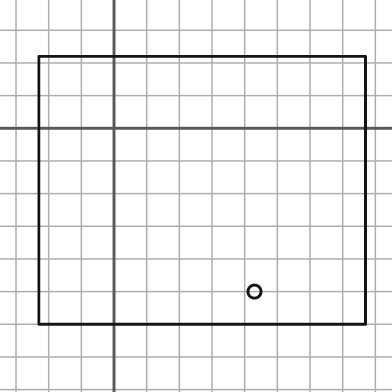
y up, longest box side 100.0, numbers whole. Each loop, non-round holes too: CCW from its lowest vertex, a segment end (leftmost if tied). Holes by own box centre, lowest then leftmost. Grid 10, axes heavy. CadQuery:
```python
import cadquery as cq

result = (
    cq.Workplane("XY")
    .moveTo(-23.0, -60.0)
    .lineTo(77.0, -60.0)
    .lineTo(77.0, 22.0)
    .lineTo(-23.0, 22.0)
    .close()
    .moveTo(43.0, -50.0)
    .circle(2.0)
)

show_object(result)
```